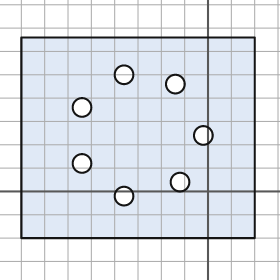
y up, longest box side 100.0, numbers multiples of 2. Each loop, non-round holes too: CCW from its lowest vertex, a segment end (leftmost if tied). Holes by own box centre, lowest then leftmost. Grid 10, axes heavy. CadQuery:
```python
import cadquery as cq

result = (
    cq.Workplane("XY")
    .moveTo(-80.0, -20.0)
    .lineTo(20.0, -20.0)
    .lineTo(20.0, 66.0)
    .lineTo(-80.0, 66.0)
    .close()
    .moveTo(-36.0, -2.0)
    .circle(4.0)
    .moveTo(-12.0, 4.0)
    .circle(4.0)
    .moveTo(-54.0, 12.0)
    .circle(4.0)
    .moveTo(-2.0, 24.0)
    .circle(4.0)
    .moveTo(-54.0, 36.0)
    .circle(4.0)
    .moveTo(-14.0, 46.0)
    .circle(4.0)
    .moveTo(-36.0, 50.0)
    .circle(4.0)
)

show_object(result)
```